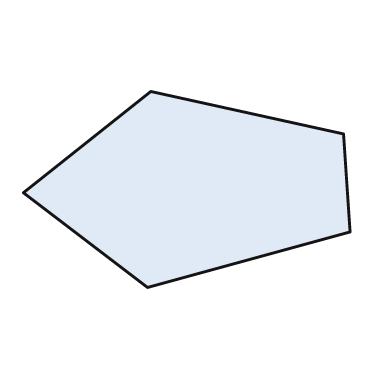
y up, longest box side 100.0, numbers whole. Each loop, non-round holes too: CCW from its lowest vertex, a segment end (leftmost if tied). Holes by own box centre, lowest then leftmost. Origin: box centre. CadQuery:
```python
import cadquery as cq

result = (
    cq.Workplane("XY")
    .moveTo(-12.0, -30.0)
    .lineTo(50.0, -13.0)
    .lineTo(48.0, 17.0)
    .lineTo(-11.0, 30.0)
    .lineTo(-50.0, -1.0)
    .close()
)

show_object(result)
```